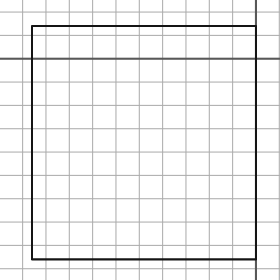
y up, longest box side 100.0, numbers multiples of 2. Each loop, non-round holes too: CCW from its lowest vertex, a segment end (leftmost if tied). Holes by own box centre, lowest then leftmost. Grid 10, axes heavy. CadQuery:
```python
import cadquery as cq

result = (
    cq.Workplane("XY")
    .moveTo(-96.0, -86.0)
    .lineTo(0.0, -86.0)
    .lineTo(0.0, 14.0)
    .lineTo(-96.0, 14.0)
    .close()
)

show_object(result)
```